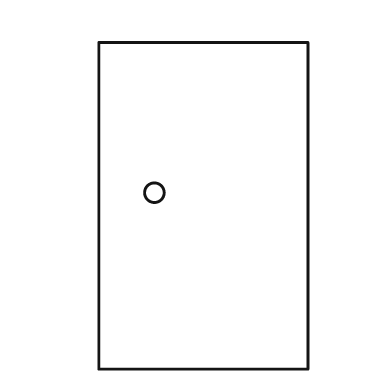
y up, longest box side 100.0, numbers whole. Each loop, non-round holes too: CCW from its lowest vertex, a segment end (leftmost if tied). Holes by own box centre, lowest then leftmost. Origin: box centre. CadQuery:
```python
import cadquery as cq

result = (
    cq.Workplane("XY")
    .moveTo(-32.0, -50.0)
    .lineTo(32.0, -50.0)
    .lineTo(32.0, 50.0)
    .lineTo(-32.0, 50.0)
    .close()
    .moveTo(-15.0, 4.0)
    .circle(3.0)
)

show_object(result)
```